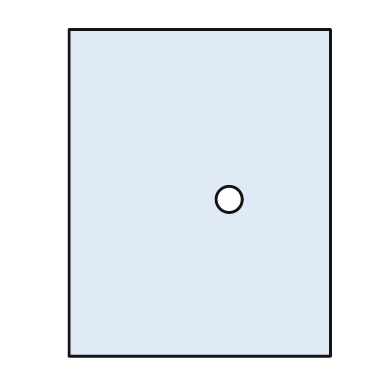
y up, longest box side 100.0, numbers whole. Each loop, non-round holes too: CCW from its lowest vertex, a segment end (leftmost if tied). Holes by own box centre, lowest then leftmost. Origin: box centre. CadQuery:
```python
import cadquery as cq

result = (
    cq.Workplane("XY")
    .moveTo(-40.0, -50.0)
    .lineTo(40.0, -50.0)
    .lineTo(40.0, 50.0)
    .lineTo(-40.0, 50.0)
    .close()
    .moveTo(9.0, -2.0)
    .circle(4.0)
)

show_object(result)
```